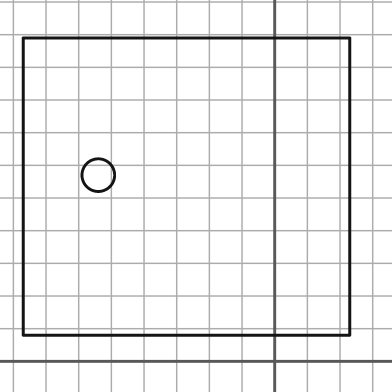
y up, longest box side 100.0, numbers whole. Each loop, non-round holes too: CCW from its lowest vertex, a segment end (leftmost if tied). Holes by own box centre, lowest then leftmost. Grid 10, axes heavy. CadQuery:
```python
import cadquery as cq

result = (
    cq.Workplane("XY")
    .moveTo(-77.0, 8.0)
    .lineTo(23.0, 8.0)
    .lineTo(23.0, 99.0)
    .lineTo(-77.0, 99.0)
    .close()
    .moveTo(-54.0, 57.0)
    .circle(5.0)
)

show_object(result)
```